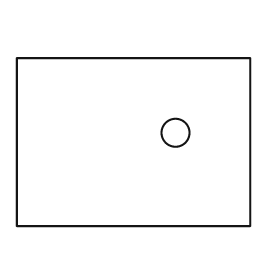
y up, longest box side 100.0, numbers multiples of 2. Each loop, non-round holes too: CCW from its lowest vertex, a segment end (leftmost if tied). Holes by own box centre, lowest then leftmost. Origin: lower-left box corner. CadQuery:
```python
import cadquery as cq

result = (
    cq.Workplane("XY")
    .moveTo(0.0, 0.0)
    .lineTo(100.0, 0.0)
    .lineTo(100.0, 72.0)
    .lineTo(0.0, 72.0)
    .close()
    .moveTo(68.0, 40.0)
    .circle(6.0)
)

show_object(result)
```